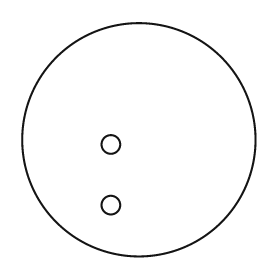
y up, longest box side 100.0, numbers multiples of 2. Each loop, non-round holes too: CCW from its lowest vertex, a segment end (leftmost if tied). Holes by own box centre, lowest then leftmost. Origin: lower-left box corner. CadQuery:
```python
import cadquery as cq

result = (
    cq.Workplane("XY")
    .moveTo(50.0, 50.0)
    .circle(50.0)
    .moveTo(38.0, 22.0)
    .circle(4.0)
    .moveTo(38.0, 48.0)
    .circle(4.0)
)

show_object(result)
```